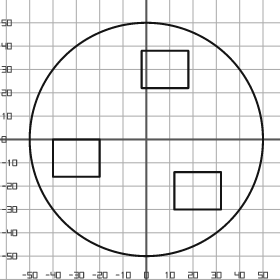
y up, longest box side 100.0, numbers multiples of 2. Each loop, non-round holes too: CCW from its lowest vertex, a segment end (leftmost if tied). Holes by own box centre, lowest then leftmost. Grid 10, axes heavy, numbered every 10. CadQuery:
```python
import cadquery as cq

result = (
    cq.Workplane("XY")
    .moveTo(0.0, 0.0)
    .circle(50.0)
    .moveTo(12.0, -30.0)
    .lineTo(32.0, -30.0)
    .lineTo(32.0, -14.0)
    .lineTo(12.0, -14.0)
    .close()
    .moveTo(-40.0, -16.0)
    .lineTo(-20.0, -16.0)
    .lineTo(-20.0, 0.0)
    .lineTo(-40.0, 0.0)
    .close()
    .moveTo(-2.0, 22.0)
    .lineTo(18.0, 22.0)
    .lineTo(18.0, 38.0)
    .lineTo(-2.0, 38.0)
    .close()
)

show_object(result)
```